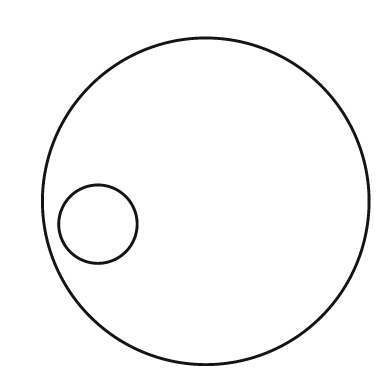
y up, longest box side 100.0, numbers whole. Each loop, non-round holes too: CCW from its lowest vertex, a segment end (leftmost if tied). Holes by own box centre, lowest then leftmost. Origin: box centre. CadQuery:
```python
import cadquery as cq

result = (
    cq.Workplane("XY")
    .moveTo(0.0, 0.0)
    .circle(50.0)
    .moveTo(-33.0, -7.0)
    .circle(12.0)
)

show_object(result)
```